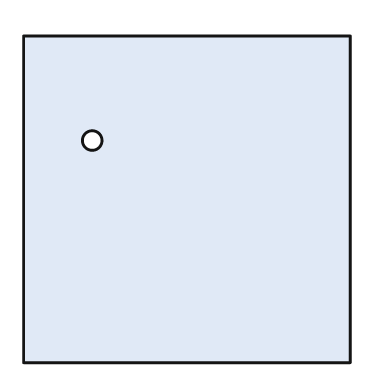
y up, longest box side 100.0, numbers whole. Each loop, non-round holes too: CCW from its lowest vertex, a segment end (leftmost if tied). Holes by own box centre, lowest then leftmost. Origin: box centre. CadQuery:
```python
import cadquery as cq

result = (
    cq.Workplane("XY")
    .moveTo(-50.0, -50.0)
    .lineTo(50.0, -50.0)
    .lineTo(50.0, 50.0)
    .lineTo(-50.0, 50.0)
    .close()
    .moveTo(-29.0, 18.0)
    .circle(3.0)
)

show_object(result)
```